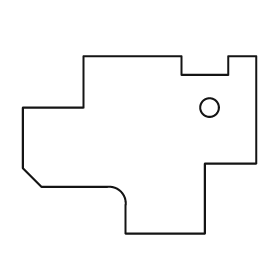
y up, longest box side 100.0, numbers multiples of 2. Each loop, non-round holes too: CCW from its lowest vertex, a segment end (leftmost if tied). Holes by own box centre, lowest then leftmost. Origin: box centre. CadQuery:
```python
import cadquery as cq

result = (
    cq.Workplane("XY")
    .moveTo(-6.0, -38.0)
    .lineTo(28.0, -38.0)
    .lineTo(28.0, -8.0)
    .lineTo(50.0, -8.0)
    .lineTo(50.0, 38.0)
    .lineTo(38.0, 38.0)
    .lineTo(38.0, 30.0)
    .lineTo(18.0, 30.0)
    .lineTo(18.0, 38.0)
    .lineTo(-24.0, 38.0)
    .lineTo(-24.0, 16.0)
    .lineTo(-50.0, 16.0)
    .lineTo(-50.0, -10.0)
    .lineTo(-42.0, -18.0)
    .lineTo(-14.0, -18.0)
    .threePointArc((-8.0, -20.0), (-6.0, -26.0))
    .close()
    .moveTo(30.0, 16.0)
    .circle(4.0)
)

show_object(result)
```